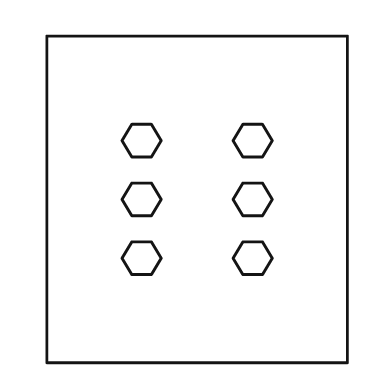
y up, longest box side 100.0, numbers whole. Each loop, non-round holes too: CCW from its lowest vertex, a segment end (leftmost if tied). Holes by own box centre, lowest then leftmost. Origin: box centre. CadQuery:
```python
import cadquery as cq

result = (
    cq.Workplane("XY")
    .moveTo(-46.0, -50.0)
    .lineTo(46.0, -50.0)
    .lineTo(46.0, 50.0)
    .lineTo(-46.0, 50.0)
    .close()
    .moveTo(-20.0, -23.0)
    .lineTo(-14.0, -23.0)
    .lineTo(-11.0, -18.0)
    .lineTo(-14.0, -13.0)
    .lineTo(-20.0, -13.0)
    .lineTo(-23.0, -18.0)
    .close()
    .moveTo(14.0, -23.0)
    .lineTo(20.0, -23.0)
    .lineTo(23.0, -18.0)
    .lineTo(20.0, -13.0)
    .lineTo(14.0, -13.0)
    .lineTo(11.0, -18.0)
    .close()
    .moveTo(-20.0, -5.0)
    .lineTo(-14.0, -5.0)
    .lineTo(-11.0, 0.0)
    .lineTo(-14.0, 5.0)
    .lineTo(-20.0, 5.0)
    .lineTo(-23.0, 0.0)
    .close()
    .moveTo(14.0, -5.0)
    .lineTo(20.0, -5.0)
    .lineTo(23.0, 0.0)
    .lineTo(20.0, 5.0)
    .lineTo(14.0, 5.0)
    .lineTo(11.0, 0.0)
    .close()
    .moveTo(-20.0, 13.0)
    .lineTo(-14.0, 13.0)
    .lineTo(-11.0, 18.0)
    .lineTo(-14.0, 23.0)
    .lineTo(-20.0, 23.0)
    .lineTo(-23.0, 18.0)
    .close()
    .moveTo(14.0, 13.0)
    .lineTo(20.0, 13.0)
    .lineTo(23.0, 18.0)
    .lineTo(20.0, 23.0)
    .lineTo(14.0, 23.0)
    .lineTo(11.0, 18.0)
    .close()
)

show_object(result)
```